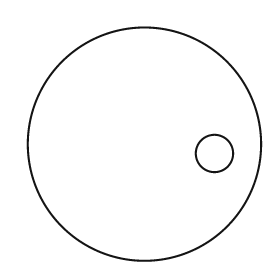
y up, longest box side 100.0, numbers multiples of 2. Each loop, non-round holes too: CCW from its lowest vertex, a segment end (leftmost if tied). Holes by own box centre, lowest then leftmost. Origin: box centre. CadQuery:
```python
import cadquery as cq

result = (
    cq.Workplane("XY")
    .moveTo(0.0, 0.0)
    .circle(50.0)
    .moveTo(30.0, -4.0)
    .circle(8.0)
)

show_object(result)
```